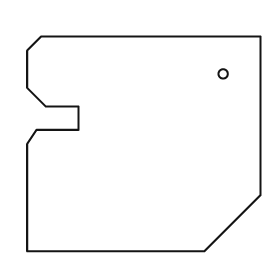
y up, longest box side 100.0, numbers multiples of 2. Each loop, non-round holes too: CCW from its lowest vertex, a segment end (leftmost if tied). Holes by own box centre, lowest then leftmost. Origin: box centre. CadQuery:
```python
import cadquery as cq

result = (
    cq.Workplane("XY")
    .moveTo(-50.0, -46.0)
    .lineTo(26.0, -46.0)
    .lineTo(50.0, -22.0)
    .lineTo(50.0, 46.0)
    .lineTo(-44.0, 46.0)
    .lineTo(-50.0, 40.0)
    .lineTo(-50.0, 24.0)
    .lineTo(-42.0, 16.0)
    .lineTo(-28.0, 16.0)
    .lineTo(-28.0, 6.0)
    .lineTo(-46.0, 6.0)
    .lineTo(-50.0, 0.0)
    .close()
    .moveTo(34.0, 30.0)
    .circle(2.0)
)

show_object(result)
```